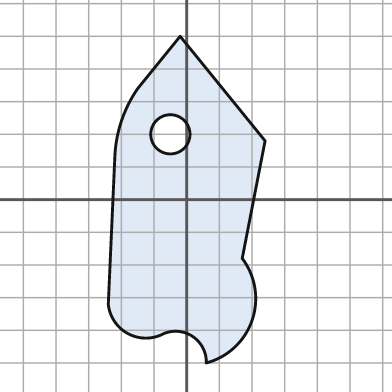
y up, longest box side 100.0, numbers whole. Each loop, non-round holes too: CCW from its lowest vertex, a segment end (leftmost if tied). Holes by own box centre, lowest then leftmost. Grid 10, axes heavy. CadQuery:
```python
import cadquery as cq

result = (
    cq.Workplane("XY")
    .moveTo(6.0, -50.0)
    .threePointArc((20.0, -37.0), (17.0, -18.0))
    .lineTo(24.0, 18.0)
    .lineTo(-2.0, 50.0)
    .lineTo(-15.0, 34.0)
    .threePointArc((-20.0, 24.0), (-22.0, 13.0))
    .lineTo(-24.0, -32.0)
    .threePointArc((-18.0, -41.0), (-7.0, -41.0))
    .threePointArc((2.0, -42.0), (6.0, -50.0))
    .close()
    .moveTo(-5.0, 20.0)
    .circle(6.0)
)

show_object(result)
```